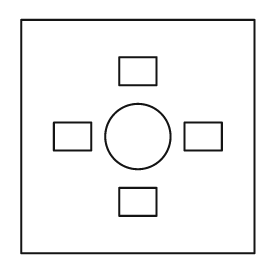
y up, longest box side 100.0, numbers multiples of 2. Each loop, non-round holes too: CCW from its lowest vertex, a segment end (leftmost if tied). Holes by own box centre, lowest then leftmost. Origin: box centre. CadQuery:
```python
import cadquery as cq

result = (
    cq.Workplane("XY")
    .moveTo(-50.0, -50.0)
    .lineTo(50.0, -50.0)
    .lineTo(50.0, 50.0)
    .lineTo(-50.0, 50.0)
    .close()
    .moveTo(-8.0, -34.0)
    .lineTo(8.0, -34.0)
    .lineTo(8.0, -22.0)
    .lineTo(-8.0, -22.0)
    .close()
    .moveTo(-36.0, -6.0)
    .lineTo(-20.0, -6.0)
    .lineTo(-20.0, 6.0)
    .lineTo(-36.0, 6.0)
    .close()
    .moveTo(0.0, 0.0)
    .circle(14.0)
    .moveTo(20.0, -6.0)
    .lineTo(36.0, -6.0)
    .lineTo(36.0, 6.0)
    .lineTo(20.0, 6.0)
    .close()
    .moveTo(-8.0, 22.0)
    .lineTo(8.0, 22.0)
    .lineTo(8.0, 34.0)
    .lineTo(-8.0, 34.0)
    .close()
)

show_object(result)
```